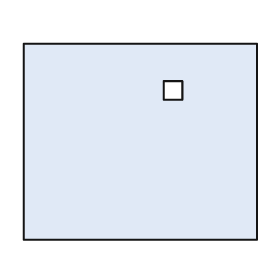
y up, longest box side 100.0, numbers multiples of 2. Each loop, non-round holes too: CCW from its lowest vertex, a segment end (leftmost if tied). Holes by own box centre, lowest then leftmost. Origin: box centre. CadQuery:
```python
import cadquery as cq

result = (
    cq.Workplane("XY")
    .moveTo(-50.0, -42.0)
    .lineTo(50.0, -42.0)
    .lineTo(50.0, 42.0)
    .lineTo(-50.0, 42.0)
    .close()
    .moveTo(10.0, 18.0)
    .lineTo(18.0, 18.0)
    .lineTo(18.0, 26.0)
    .lineTo(10.0, 26.0)
    .close()
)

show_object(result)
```